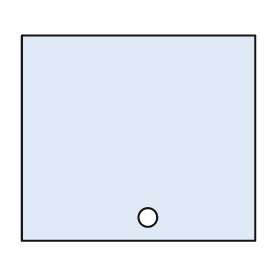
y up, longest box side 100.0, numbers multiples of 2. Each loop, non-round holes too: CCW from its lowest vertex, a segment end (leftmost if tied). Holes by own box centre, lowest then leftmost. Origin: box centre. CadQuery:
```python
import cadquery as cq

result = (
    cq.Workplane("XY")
    .moveTo(-50.0, -44.0)
    .lineTo(50.0, -44.0)
    .lineTo(50.0, 44.0)
    .lineTo(-50.0, 44.0)
    .close()
    .moveTo(4.0, -34.0)
    .circle(4.0)
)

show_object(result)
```